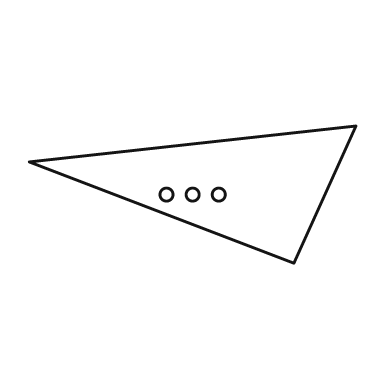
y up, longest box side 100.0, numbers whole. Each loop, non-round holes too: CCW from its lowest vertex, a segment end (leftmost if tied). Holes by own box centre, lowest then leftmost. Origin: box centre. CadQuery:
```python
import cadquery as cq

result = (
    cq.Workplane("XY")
    .moveTo(31.0, -21.0)
    .lineTo(50.0, 21.0)
    .lineTo(-50.0, 10.0)
    .close()
    .moveTo(-8.0, 0.0)
    .circle(2.0)
    .moveTo(0.0, 0.0)
    .circle(2.0)
    .moveTo(8.0, 0.0)
    .circle(2.0)
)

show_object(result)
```